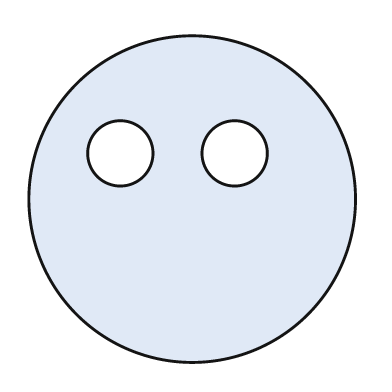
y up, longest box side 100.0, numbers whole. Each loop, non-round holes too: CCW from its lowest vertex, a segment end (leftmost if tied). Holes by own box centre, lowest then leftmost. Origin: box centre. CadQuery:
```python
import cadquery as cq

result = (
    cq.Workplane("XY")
    .moveTo(0.0, 0.0)
    .circle(50.0)
    .moveTo(-22.0, 14.0)
    .circle(10.0)
    .moveTo(13.0, 14.0)
    .circle(10.0)
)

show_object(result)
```